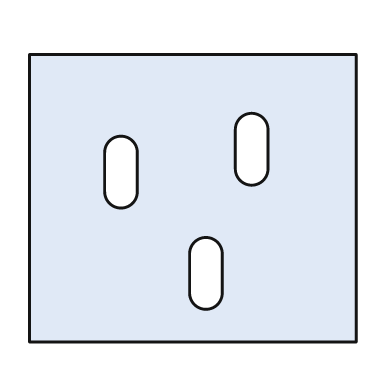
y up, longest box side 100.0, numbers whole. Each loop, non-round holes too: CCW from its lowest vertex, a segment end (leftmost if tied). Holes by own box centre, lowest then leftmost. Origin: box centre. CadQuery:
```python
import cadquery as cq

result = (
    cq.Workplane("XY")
    .moveTo(-50.0, -44.0)
    .lineTo(50.0, -44.0)
    .lineTo(50.0, 44.0)
    .lineTo(-50.0, 44.0)
    .close()
    .moveTo(-1.0, -29.0)
    .threePointArc((4.0, -34.0), (9.0, -29.0))
    .lineTo(9.0, -17.0)
    .threePointArc((4.0, -12.0), (-1.0, -17.0))
    .close()
    .moveTo(-27.0, 2.0)
    .threePointArc((-22.0, -3.0), (-17.0, 2.0))
    .lineTo(-17.0, 14.0)
    .threePointArc((-22.0, 19.0), (-27.0, 14.0))
    .close()
    .moveTo(13.0, 9.0)
    .threePointArc((18.0, 4.0), (23.0, 9.0))
    .lineTo(23.0, 21.0)
    .threePointArc((18.0, 26.0), (13.0, 21.0))
    .close()
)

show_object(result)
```